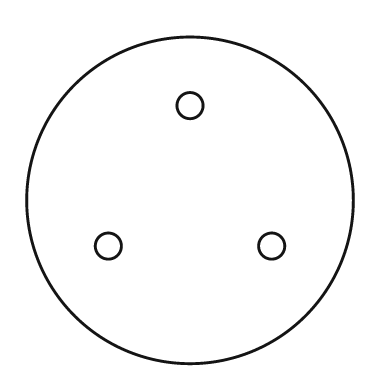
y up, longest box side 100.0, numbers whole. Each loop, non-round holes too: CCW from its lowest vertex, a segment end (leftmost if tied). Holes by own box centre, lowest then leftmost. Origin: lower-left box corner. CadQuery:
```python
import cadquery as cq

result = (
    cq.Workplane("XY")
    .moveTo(50.0, 50.0)
    .circle(50.0)
    .moveTo(25.0, 36.0)
    .circle(4.0)
    .moveTo(75.0, 36.0)
    .circle(4.0)
    .moveTo(50.0, 79.0)
    .circle(4.0)
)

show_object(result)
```